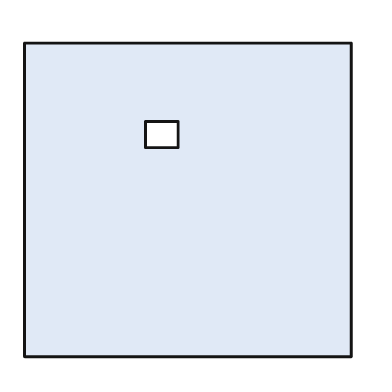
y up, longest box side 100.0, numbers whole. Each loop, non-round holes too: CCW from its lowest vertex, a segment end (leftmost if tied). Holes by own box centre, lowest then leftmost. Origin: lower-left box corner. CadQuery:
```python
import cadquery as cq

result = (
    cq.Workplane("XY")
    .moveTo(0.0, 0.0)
    .lineTo(100.0, 0.0)
    .lineTo(100.0, 96.0)
    .lineTo(0.0, 96.0)
    .close()
    .moveTo(37.0, 64.0)
    .lineTo(47.0, 64.0)
    .lineTo(47.0, 72.0)
    .lineTo(37.0, 72.0)
    .close()
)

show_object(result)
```